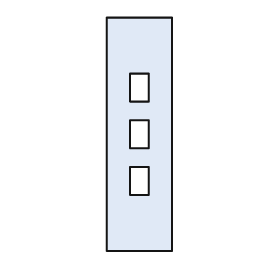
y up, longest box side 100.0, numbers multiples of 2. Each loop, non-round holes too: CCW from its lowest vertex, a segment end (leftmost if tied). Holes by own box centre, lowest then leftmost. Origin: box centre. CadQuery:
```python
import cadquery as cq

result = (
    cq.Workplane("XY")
    .moveTo(-14.0, -50.0)
    .lineTo(14.0, -50.0)
    .lineTo(14.0, 50.0)
    .lineTo(-14.0, 50.0)
    .close()
    .moveTo(-4.0, -26.0)
    .lineTo(4.0, -26.0)
    .lineTo(4.0, -14.0)
    .lineTo(-4.0, -14.0)
    .close()
    .moveTo(-4.0, -6.0)
    .lineTo(4.0, -6.0)
    .lineTo(4.0, 6.0)
    .lineTo(-4.0, 6.0)
    .close()
    .moveTo(-4.0, 14.0)
    .lineTo(4.0, 14.0)
    .lineTo(4.0, 26.0)
    .lineTo(-4.0, 26.0)
    .close()
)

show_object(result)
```